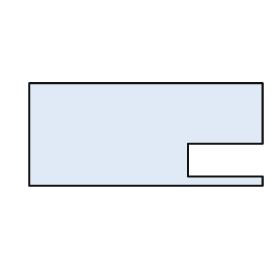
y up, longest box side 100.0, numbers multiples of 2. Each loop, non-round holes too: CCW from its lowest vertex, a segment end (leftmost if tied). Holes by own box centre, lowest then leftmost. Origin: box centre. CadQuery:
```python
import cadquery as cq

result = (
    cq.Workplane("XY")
    .moveTo(-50.0, -22.0)
    .lineTo(50.0, -22.0)
    .lineTo(50.0, -18.0)
    .lineTo(18.0, -18.0)
    .lineTo(18.0, -4.0)
    .lineTo(50.0, -4.0)
    .lineTo(50.0, 22.0)
    .lineTo(-50.0, 22.0)
    .close()
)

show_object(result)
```